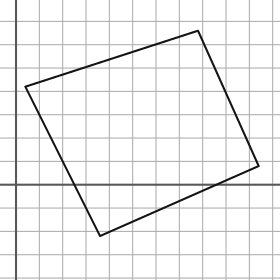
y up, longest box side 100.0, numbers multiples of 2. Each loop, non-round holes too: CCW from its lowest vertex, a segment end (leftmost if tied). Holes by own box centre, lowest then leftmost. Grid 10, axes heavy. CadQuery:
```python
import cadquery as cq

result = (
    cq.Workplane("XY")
    .moveTo(36.0, -22.0)
    .lineTo(104.0, 8.0)
    .lineTo(78.0, 66.0)
    .lineTo(4.0, 42.0)
    .close()
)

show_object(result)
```